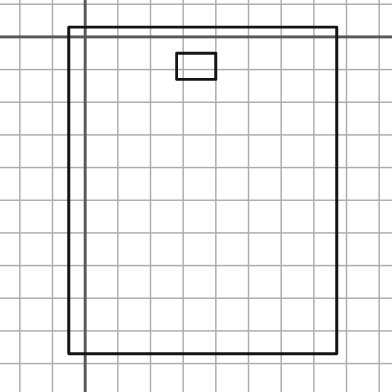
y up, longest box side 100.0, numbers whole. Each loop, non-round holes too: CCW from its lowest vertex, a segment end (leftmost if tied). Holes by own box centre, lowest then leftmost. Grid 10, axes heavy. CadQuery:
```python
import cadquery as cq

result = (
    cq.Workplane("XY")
    .moveTo(-5.0, -97.0)
    .lineTo(77.0, -97.0)
    .lineTo(77.0, 3.0)
    .lineTo(-5.0, 3.0)
    .close()
    .moveTo(28.0, -13.0)
    .lineTo(40.0, -13.0)
    .lineTo(40.0, -5.0)
    .lineTo(28.0, -5.0)
    .close()
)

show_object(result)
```